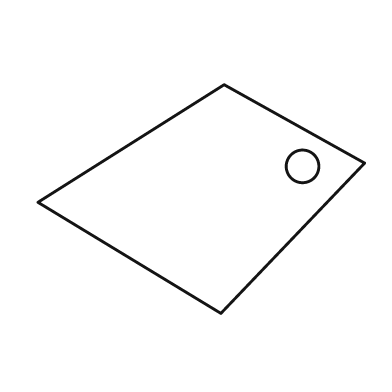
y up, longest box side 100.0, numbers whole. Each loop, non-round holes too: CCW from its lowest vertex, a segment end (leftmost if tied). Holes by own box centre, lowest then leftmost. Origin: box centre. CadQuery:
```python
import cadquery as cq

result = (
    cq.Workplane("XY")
    .moveTo(6.0, -35.0)
    .lineTo(50.0, 11.0)
    .lineTo(7.0, 35.0)
    .lineTo(-50.0, -1.0)
    .close()
    .moveTo(31.0, 10.0)
    .circle(5.0)
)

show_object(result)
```